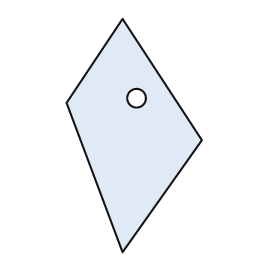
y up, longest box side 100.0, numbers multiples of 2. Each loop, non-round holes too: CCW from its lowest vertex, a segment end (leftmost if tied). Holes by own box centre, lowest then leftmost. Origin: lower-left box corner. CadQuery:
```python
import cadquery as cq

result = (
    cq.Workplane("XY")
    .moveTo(24.0, 0.0)
    .lineTo(58.0, 48.0)
    .lineTo(24.0, 100.0)
    .lineTo(0.0, 64.0)
    .close()
    .moveTo(30.0, 66.0)
    .circle(4.0)
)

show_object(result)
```